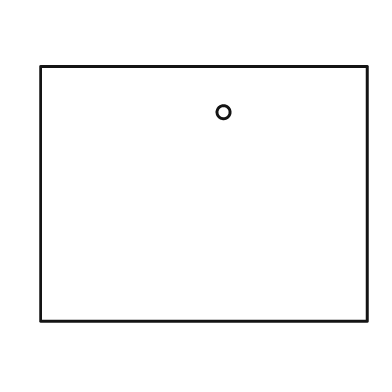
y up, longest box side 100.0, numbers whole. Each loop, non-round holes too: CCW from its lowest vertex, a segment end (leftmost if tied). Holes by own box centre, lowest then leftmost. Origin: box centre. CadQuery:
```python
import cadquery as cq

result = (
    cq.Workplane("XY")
    .moveTo(-50.0, -39.0)
    .lineTo(50.0, -39.0)
    .lineTo(50.0, 39.0)
    .lineTo(-50.0, 39.0)
    .close()
    .moveTo(6.0, 25.0)
    .circle(2.0)
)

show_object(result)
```